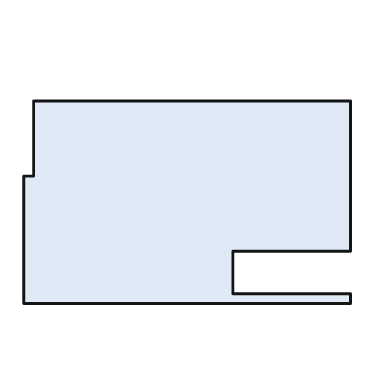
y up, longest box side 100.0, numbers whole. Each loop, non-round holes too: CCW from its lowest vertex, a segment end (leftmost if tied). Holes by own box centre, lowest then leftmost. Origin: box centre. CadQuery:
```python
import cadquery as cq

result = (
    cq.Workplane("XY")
    .moveTo(-50.0, -31.0)
    .lineTo(50.0, -31.0)
    .lineTo(50.0, -28.0)
    .lineTo(14.0, -28.0)
    .lineTo(14.0, -15.0)
    .lineTo(50.0, -15.0)
    .lineTo(50.0, 31.0)
    .lineTo(-47.0, 31.0)
    .lineTo(-47.0, 8.0)
    .lineTo(-50.0, 8.0)
    .close()
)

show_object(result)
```